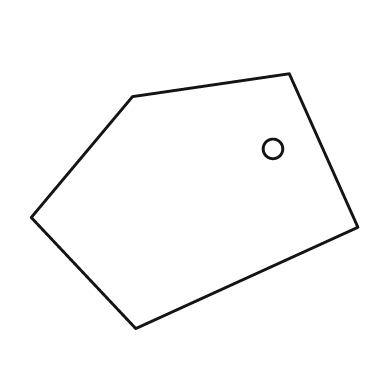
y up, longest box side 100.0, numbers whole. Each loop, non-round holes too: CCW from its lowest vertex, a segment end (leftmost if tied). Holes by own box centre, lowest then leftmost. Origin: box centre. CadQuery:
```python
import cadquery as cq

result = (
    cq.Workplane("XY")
    .moveTo(-18.0, -39.0)
    .lineTo(50.0, -8.0)
    .lineTo(29.0, 39.0)
    .lineTo(-19.0, 32.0)
    .lineTo(-50.0, -5.0)
    .close()
    .moveTo(24.0, 16.0)
    .circle(3.0)
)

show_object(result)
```